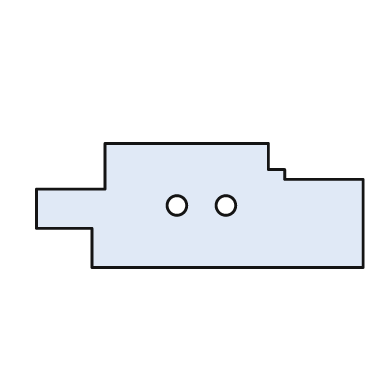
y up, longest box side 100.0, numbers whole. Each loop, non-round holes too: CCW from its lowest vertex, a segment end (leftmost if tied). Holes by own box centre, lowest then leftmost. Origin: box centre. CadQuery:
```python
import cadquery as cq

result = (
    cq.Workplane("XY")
    .moveTo(-33.0, -19.0)
    .lineTo(50.0, -19.0)
    .lineTo(50.0, 8.0)
    .lineTo(26.0, 8.0)
    .lineTo(26.0, 11.0)
    .lineTo(21.0, 11.0)
    .lineTo(21.0, 19.0)
    .lineTo(-29.0, 19.0)
    .lineTo(-29.0, 5.0)
    .lineTo(-50.0, 5.0)
    .lineTo(-50.0, -7.0)
    .lineTo(-33.0, -7.0)
    .close()
    .moveTo(-7.0, 0.0)
    .circle(3.0)
    .moveTo(8.0, 0.0)
    .circle(3.0)
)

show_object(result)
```